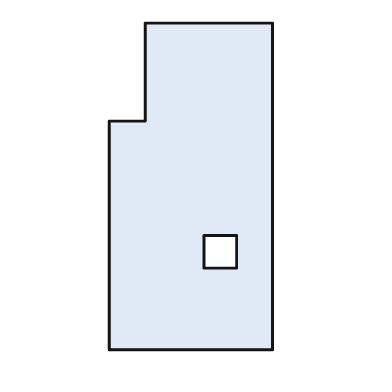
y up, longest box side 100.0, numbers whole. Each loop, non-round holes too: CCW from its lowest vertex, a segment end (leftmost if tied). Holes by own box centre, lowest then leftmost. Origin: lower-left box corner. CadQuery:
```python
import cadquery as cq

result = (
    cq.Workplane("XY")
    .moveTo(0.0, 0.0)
    .lineTo(50.0, 0.0)
    .lineTo(50.0, 100.0)
    .lineTo(11.0, 100.0)
    .lineTo(11.0, 70.0)
    .lineTo(0.0, 70.0)
    .close()
    .moveTo(29.0, 25.0)
    .lineTo(39.0, 25.0)
    .lineTo(39.0, 35.0)
    .lineTo(29.0, 35.0)
    .close()
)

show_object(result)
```